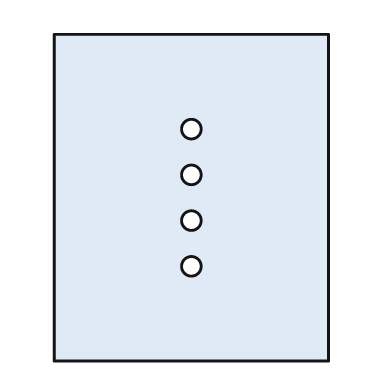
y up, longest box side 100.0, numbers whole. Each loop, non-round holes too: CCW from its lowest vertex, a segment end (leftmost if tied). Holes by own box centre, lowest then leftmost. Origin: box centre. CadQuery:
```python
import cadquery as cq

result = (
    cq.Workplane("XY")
    .moveTo(-42.0, -50.0)
    .lineTo(42.0, -50.0)
    .lineTo(42.0, 50.0)
    .lineTo(-42.0, 50.0)
    .close()
    .moveTo(0.0, -21.0)
    .circle(3.0)
    .moveTo(0.0, -7.0)
    .circle(3.0)
    .moveTo(0.0, 7.0)
    .circle(3.0)
    .moveTo(0.0, 21.0)
    .circle(3.0)
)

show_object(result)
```